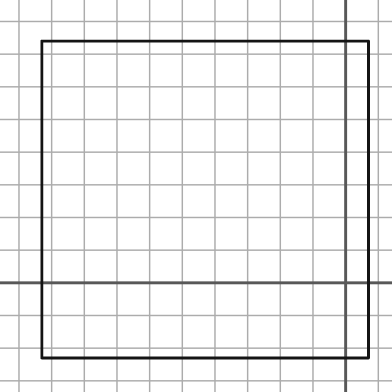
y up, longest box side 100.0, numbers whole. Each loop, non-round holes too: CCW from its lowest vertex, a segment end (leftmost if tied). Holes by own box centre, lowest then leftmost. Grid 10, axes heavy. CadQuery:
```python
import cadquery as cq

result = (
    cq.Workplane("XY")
    .moveTo(-93.0, -23.0)
    .lineTo(7.0, -23.0)
    .lineTo(7.0, 74.0)
    .lineTo(-93.0, 74.0)
    .close()
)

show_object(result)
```